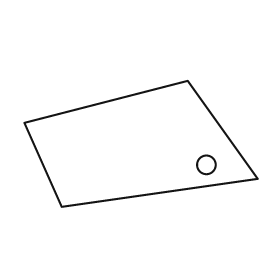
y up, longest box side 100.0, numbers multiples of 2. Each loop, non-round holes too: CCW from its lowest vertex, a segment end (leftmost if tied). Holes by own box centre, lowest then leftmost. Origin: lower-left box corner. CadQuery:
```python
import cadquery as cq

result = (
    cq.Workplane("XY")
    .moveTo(16.0, 0.0)
    .lineTo(100.0, 12.0)
    .lineTo(70.0, 54.0)
    .lineTo(0.0, 36.0)
    .close()
    .moveTo(78.0, 18.0)
    .circle(4.0)
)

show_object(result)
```